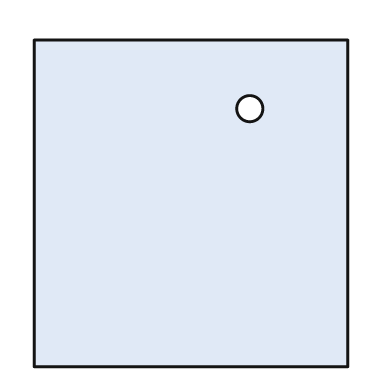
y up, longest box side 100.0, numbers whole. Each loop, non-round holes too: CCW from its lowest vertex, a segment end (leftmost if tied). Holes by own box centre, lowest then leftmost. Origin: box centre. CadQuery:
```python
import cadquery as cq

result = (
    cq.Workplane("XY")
    .moveTo(-48.0, -50.0)
    .lineTo(48.0, -50.0)
    .lineTo(48.0, 50.0)
    .lineTo(-48.0, 50.0)
    .close()
    .moveTo(18.0, 29.0)
    .circle(4.0)
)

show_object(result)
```